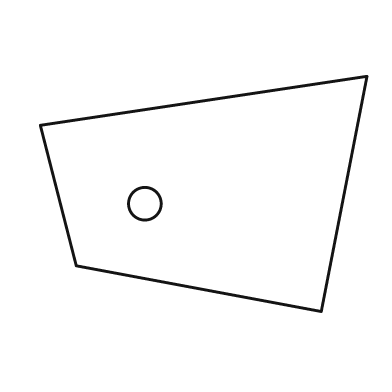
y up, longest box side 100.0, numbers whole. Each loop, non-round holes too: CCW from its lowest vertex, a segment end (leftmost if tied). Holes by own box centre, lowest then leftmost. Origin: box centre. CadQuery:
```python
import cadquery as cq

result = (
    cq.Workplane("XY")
    .moveTo(36.0, -36.0)
    .lineTo(50.0, 36.0)
    .lineTo(-50.0, 21.0)
    .lineTo(-39.0, -22.0)
    .close()
    .moveTo(-18.0, -3.0)
    .circle(5.0)
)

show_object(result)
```